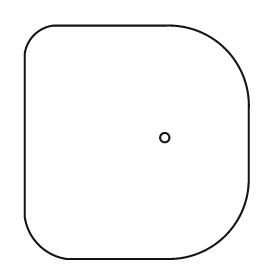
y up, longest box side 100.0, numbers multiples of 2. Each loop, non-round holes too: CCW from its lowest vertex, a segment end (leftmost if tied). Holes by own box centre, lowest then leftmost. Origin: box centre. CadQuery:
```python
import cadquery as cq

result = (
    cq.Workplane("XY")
    .moveTo(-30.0, -50.0)
    .lineTo(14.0, -50.0)
    .threePointArc((38.0, -40.0), (48.0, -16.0))
    .lineTo(48.0, 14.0)
    .threePointArc((38.0, 40.0), (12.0, 50.0))
    .lineTo(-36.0, 50.0)
    .threePointArc((-44.0, 46.0), (-48.0, 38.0))
    .lineTo(-48.0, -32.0)
    .threePointArc((-42.0, -44.0), (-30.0, -50.0))
    .close()
    .moveTo(12.0, 2.0)
    .circle(2.0)
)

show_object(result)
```